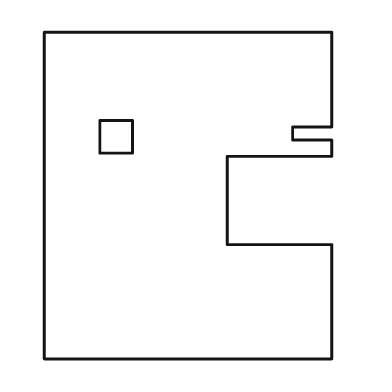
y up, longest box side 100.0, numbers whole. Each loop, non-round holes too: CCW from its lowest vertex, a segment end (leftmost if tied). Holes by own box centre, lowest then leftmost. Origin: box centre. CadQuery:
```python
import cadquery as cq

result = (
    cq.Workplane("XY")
    .moveTo(-44.0, -50.0)
    .lineTo(44.0, -50.0)
    .lineTo(44.0, -15.0)
    .lineTo(12.0, -15.0)
    .lineTo(12.0, 12.0)
    .lineTo(44.0, 12.0)
    .lineTo(44.0, 17.0)
    .lineTo(32.0, 17.0)
    .lineTo(32.0, 21.0)
    .lineTo(44.0, 21.0)
    .lineTo(44.0, 50.0)
    .lineTo(-44.0, 50.0)
    .close()
    .moveTo(-27.0, 13.0)
    .lineTo(-17.0, 13.0)
    .lineTo(-17.0, 23.0)
    .lineTo(-27.0, 23.0)
    .close()
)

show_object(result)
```